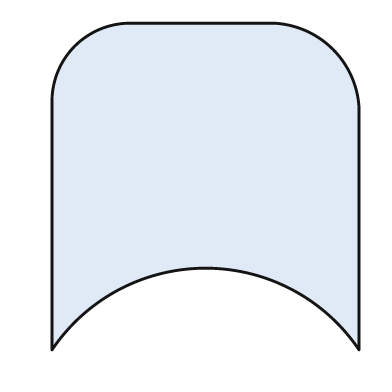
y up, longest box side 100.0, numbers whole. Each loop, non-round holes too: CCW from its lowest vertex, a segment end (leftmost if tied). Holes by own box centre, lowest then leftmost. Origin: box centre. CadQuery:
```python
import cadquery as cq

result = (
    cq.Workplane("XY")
    .moveTo(-47.0, -50.0)
    .threePointArc((0.0, -25.0), (47.0, -50.0))
    .lineTo(47.0, 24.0)
    .threePointArc((39.0, 42.0), (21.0, 50.0))
    .lineTo(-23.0, 50.0)
    .threePointArc((-40.0, 43.0), (-47.0, 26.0))
    .close()
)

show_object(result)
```